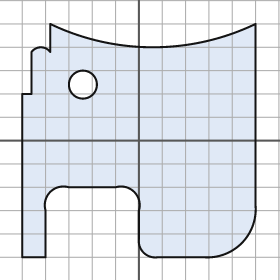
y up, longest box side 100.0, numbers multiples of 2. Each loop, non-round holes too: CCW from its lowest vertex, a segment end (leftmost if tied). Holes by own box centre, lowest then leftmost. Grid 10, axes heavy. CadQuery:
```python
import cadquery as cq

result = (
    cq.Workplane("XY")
    .moveTo(-50.0, -50.0)
    .lineTo(-40.0, -50.0)
    .lineTo(-40.0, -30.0)
    .threePointArc((-38.0, -22.0), (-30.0, -20.0))
    .lineTo(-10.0, -20.0)
    .threePointArc((-2.0, -22.0), (0.0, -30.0))
    .lineTo(0.0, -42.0)
    .threePointArc((2.0, -48.0), (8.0, -50.0))
    .lineTo(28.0, -50.0)
    .threePointArc((44.0, -44.0), (50.0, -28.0))
    .lineTo(50.0, 50.0)
    .threePointArc((6.0, 40.0), (-38.0, 50.0))
    .lineTo(-38.0, 38.0)
    .threePointArc((-42.0, 40.0), (-46.0, 38.0))
    .lineTo(-46.0, 20.0)
    .lineTo(-50.0, 20.0)
    .close()
    .moveTo(-24.0, 24.0)
    .circle(6.0)
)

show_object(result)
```